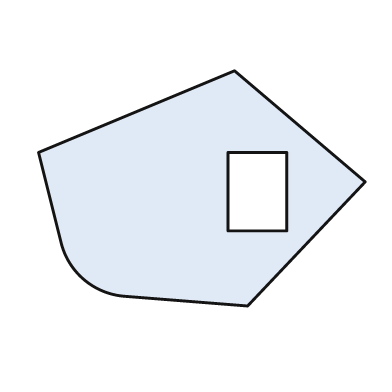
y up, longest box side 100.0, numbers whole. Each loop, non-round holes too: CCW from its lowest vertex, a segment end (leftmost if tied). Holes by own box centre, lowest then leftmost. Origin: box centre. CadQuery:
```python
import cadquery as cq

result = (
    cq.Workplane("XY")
    .moveTo(14.0, -36.0)
    .lineTo(50.0, 2.0)
    .lineTo(10.0, 36.0)
    .lineTo(-50.0, 11.0)
    .lineTo(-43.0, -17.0)
    .threePointArc((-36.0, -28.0), (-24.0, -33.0))
    .close()
    .moveTo(8.0, -13.0)
    .lineTo(26.0, -13.0)
    .lineTo(26.0, 11.0)
    .lineTo(8.0, 11.0)
    .close()
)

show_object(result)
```